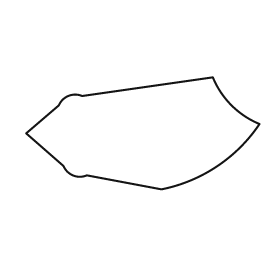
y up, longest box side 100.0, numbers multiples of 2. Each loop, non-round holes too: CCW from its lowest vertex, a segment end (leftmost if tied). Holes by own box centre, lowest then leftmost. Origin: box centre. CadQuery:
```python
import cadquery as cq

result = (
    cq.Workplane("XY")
    .moveTo(8.0, -24.0)
    .threePointArc((32.0, -14.0), (50.0, 4.0))
    .threePointArc((38.0, 12.0), (30.0, 24.0))
    .lineTo(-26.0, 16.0)
    .threePointArc((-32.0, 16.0), (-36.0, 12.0))
    .lineTo(-50.0, 0.0)
    .lineTo(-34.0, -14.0)
    .threePointArc((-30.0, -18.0), (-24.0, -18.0))
    .close()
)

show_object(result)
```